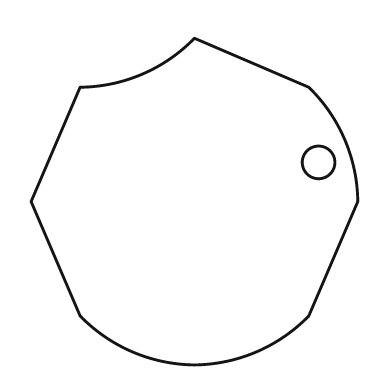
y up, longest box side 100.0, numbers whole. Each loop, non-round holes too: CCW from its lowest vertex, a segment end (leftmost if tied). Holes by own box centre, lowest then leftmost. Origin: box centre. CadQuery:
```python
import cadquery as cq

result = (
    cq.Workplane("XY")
    .moveTo(0.0, -50.0)
    .threePointArc((19.0, -46.0), (35.0, -35.0))
    .lineTo(50.0, 0.0)
    .threePointArc((46.0, 19.0), (35.0, 35.0))
    .lineTo(0.0, 50.0)
    .threePointArc((-16.0, 39.0), (-35.0, 35.0))
    .lineTo(-50.0, 0.0)
    .lineTo(-35.0, -35.0)
    .threePointArc((-19.0, -46.0), (0.0, -50.0))
    .close()
    .moveTo(38.0, 12.0)
    .circle(5.0)
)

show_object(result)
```